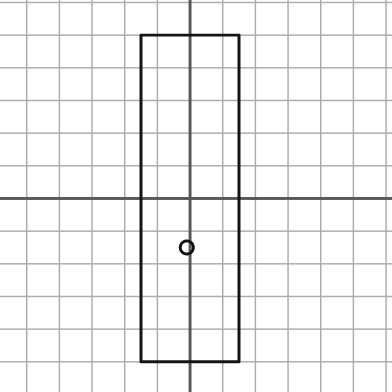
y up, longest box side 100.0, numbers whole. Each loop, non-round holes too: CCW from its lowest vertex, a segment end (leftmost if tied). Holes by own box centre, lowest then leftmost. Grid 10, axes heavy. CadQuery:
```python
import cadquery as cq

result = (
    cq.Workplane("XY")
    .moveTo(-15.0, -50.0)
    .lineTo(15.0, -50.0)
    .lineTo(15.0, 50.0)
    .lineTo(-15.0, 50.0)
    .close()
    .moveTo(-1.0, -15.0)
    .circle(2.0)
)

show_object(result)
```